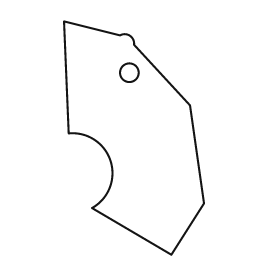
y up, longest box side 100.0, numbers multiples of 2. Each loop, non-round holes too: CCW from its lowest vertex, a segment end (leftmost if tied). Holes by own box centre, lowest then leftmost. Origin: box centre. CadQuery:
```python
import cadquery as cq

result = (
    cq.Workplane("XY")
    .moveTo(16.0, -50.0)
    .lineTo(30.0, -28.0)
    .lineTo(24.0, 14.0)
    .lineTo(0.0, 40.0)
    .threePointArc((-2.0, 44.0), (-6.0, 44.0))
    .lineTo(-30.0, 50.0)
    .lineTo(-28.0, 2.0)
    .threePointArc((-10.0, -10.0), (-18.0, -30.0))
    .close()
    .moveTo(-2.0, 28.0)
    .circle(4.0)
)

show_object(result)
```